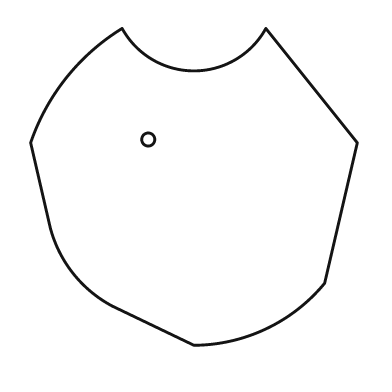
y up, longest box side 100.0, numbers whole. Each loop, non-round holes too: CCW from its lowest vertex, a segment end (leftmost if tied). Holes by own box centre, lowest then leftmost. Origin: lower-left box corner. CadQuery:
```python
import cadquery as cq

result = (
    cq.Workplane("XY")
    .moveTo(50.0, 0.0)
    .threePointArc((72.0, 5.0), (90.0, 19.0))
    .lineTo(100.0, 62.0)
    .lineTo(72.0, 97.0)
    .threePointArc((50.0, 84.0), (28.0, 97.0))
    .threePointArc((11.0, 82.0), (0.0, 62.0))
    .lineTo(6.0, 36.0)
    .threePointArc((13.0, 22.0), (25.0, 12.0))
    .close()
    .moveTo(36.0, 63.0)
    .circle(2.0)
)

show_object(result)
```